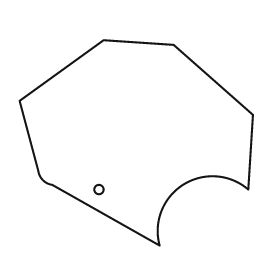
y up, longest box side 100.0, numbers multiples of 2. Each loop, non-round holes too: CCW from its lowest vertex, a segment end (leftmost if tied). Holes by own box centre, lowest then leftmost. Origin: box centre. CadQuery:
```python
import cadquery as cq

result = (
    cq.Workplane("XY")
    .moveTo(10.0, -44.0)
    .threePointArc((20.0, -18.0), (48.0, -20.0))
    .lineTo(50.0, 12.0)
    .lineTo(16.0, 42.0)
    .lineTo(-14.0, 44.0)
    .lineTo(-50.0, 18.0)
    .lineTo(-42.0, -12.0)
    .threePointArc((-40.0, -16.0), (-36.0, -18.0))
    .close()
    .moveTo(-16.0, -20.0)
    .circle(2.0)
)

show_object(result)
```